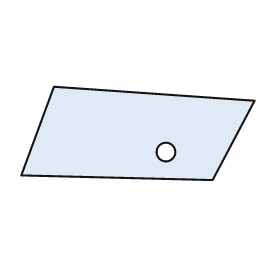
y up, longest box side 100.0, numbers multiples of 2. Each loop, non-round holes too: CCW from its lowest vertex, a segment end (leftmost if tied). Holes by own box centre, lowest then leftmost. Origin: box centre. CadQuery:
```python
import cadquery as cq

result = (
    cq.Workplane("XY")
    .moveTo(32.0, -20.0)
    .lineTo(50.0, 14.0)
    .lineTo(-36.0, 20.0)
    .lineTo(-50.0, -18.0)
    .close()
    .moveTo(12.0, -8.0)
    .circle(4.0)
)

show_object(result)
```